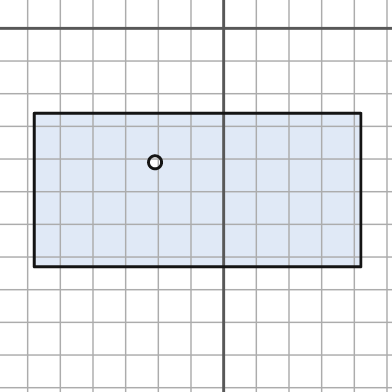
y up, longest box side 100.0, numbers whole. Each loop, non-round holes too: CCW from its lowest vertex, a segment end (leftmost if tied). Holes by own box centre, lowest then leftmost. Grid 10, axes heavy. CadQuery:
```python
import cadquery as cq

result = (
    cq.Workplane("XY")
    .moveTo(-58.0, -73.0)
    .lineTo(42.0, -73.0)
    .lineTo(42.0, -26.0)
    .lineTo(-58.0, -26.0)
    .close()
    .moveTo(-21.0, -41.0)
    .circle(2.0)
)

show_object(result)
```